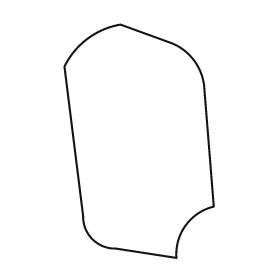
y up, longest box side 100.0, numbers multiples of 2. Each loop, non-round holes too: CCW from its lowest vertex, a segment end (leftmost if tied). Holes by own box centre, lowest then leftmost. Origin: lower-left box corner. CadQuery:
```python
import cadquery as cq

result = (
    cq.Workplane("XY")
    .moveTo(48.0, 0.0)
    .threePointArc((52.0, 14.0), (64.0, 22.0))
    .lineTo(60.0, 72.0)
    .threePointArc((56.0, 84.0), (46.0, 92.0))
    .lineTo(24.0, 100.0)
    .threePointArc((10.0, 94.0), (0.0, 82.0))
    .lineTo(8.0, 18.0)
    .threePointArc((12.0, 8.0), (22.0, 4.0))
    .close()
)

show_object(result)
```